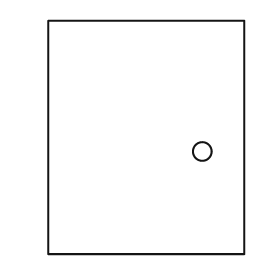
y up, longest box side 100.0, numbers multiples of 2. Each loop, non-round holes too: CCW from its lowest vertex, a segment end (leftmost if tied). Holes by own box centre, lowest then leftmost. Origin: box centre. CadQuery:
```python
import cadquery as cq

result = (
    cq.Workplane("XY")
    .moveTo(-42.0, -50.0)
    .lineTo(42.0, -50.0)
    .lineTo(42.0, 50.0)
    .lineTo(-42.0, 50.0)
    .close()
    .moveTo(24.0, -6.0)
    .circle(4.0)
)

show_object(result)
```